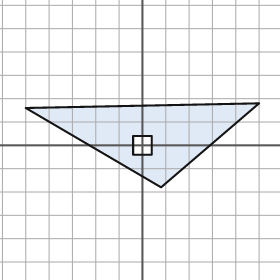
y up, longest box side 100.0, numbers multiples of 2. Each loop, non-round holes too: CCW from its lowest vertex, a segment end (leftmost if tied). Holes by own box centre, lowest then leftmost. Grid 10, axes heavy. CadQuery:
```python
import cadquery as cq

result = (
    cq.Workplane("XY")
    .moveTo(8.0, -18.0)
    .lineTo(50.0, 18.0)
    .lineTo(-50.0, 16.0)
    .close()
    .moveTo(-4.0, -4.0)
    .lineTo(4.0, -4.0)
    .lineTo(4.0, 4.0)
    .lineTo(-4.0, 4.0)
    .close()
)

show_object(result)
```